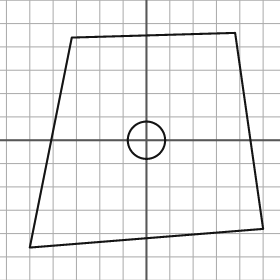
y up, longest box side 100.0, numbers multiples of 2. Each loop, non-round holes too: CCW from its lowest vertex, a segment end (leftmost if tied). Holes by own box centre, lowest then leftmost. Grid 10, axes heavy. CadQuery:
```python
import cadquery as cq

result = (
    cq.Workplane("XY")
    .moveTo(-50.0, -46.0)
    .lineTo(50.0, -38.0)
    .lineTo(38.0, 46.0)
    .lineTo(-32.0, 44.0)
    .close()
    .moveTo(0.0, 0.0)
    .circle(8.0)
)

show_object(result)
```